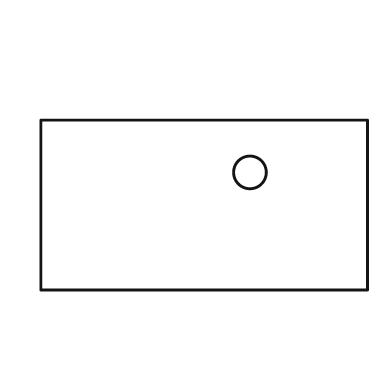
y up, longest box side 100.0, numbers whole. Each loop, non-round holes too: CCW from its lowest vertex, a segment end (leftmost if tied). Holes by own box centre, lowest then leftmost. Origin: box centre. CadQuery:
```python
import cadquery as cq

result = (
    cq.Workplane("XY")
    .moveTo(-50.0, -26.0)
    .lineTo(50.0, -26.0)
    .lineTo(50.0, 26.0)
    .lineTo(-50.0, 26.0)
    .close()
    .moveTo(14.0, 10.0)
    .circle(5.0)
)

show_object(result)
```